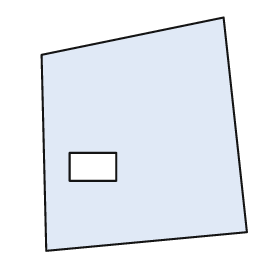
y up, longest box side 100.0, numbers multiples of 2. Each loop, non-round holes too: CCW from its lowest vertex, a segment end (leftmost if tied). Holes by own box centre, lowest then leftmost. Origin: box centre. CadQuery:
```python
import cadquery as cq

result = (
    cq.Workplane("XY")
    .moveTo(-42.0, -50.0)
    .lineTo(44.0, -42.0)
    .lineTo(34.0, 50.0)
    .lineTo(-44.0, 34.0)
    .close()
    .moveTo(-32.0, -20.0)
    .lineTo(-12.0, -20.0)
    .lineTo(-12.0, -8.0)
    .lineTo(-32.0, -8.0)
    .close()
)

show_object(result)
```